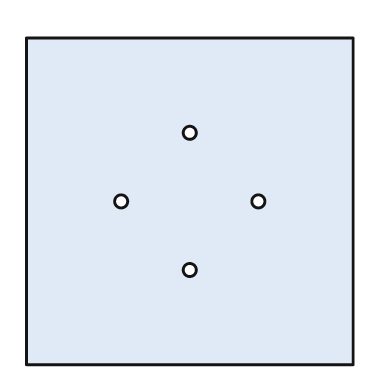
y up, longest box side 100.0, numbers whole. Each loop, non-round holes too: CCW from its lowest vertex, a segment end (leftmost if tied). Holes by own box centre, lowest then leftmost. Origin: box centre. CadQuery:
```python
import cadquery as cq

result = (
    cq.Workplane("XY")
    .moveTo(-50.0, -50.0)
    .lineTo(50.0, -50.0)
    .lineTo(50.0, 50.0)
    .lineTo(-50.0, 50.0)
    .close()
    .moveTo(0.0, -21.0)
    .circle(2.0)
    .moveTo(-21.0, 0.0)
    .circle(2.0)
    .moveTo(21.0, 0.0)
    .circle(2.0)
    .moveTo(0.0, 21.0)
    .circle(2.0)
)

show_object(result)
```